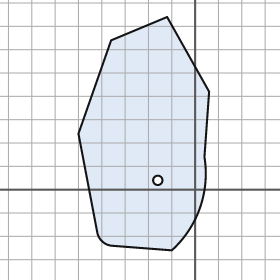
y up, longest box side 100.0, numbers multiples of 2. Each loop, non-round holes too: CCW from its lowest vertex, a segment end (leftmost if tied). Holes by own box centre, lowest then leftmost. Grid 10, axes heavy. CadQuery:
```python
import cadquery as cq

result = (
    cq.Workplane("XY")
    .moveTo(-10.0, -26.0)
    .threePointArc((2.0, -8.0), (4.0, 14.0))
    .lineTo(6.0, 42.0)
    .lineTo(-12.0, 74.0)
    .lineTo(-36.0, 64.0)
    .lineTo(-50.0, 24.0)
    .lineTo(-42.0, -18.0)
    .threePointArc((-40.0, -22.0), (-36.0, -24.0))
    .close()
    .moveTo(-16.0, 4.0)
    .circle(2.0)
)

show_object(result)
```